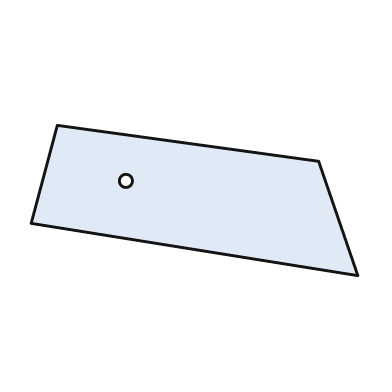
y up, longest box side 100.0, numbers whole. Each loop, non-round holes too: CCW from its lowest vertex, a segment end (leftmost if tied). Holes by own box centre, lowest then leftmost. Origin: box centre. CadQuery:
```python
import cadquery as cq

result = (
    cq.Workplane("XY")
    .moveTo(50.0, -23.0)
    .lineTo(38.0, 12.0)
    .lineTo(-42.0, 23.0)
    .lineTo(-50.0, -7.0)
    .close()
    .moveTo(-21.0, 6.0)
    .circle(2.0)
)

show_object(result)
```